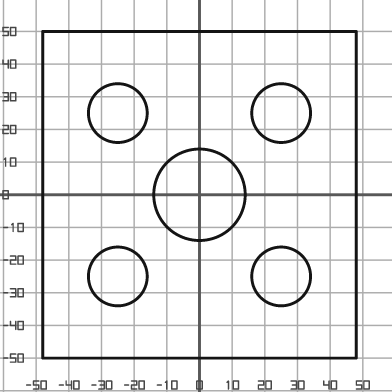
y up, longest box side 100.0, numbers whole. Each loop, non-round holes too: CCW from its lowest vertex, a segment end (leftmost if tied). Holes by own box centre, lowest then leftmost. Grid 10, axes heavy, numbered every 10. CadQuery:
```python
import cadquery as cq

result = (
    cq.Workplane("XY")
    .moveTo(-48.0, -50.0)
    .lineTo(48.0, -50.0)
    .lineTo(48.0, 50.0)
    .lineTo(-48.0, 50.0)
    .close()
    .moveTo(-25.0, -25.0)
    .circle(9.0)
    .moveTo(25.0, -25.0)
    .circle(9.0)
    .moveTo(0.0, 0.0)
    .circle(14.0)
    .moveTo(-25.0, 25.0)
    .circle(9.0)
    .moveTo(25.0, 25.0)
    .circle(9.0)
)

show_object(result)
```